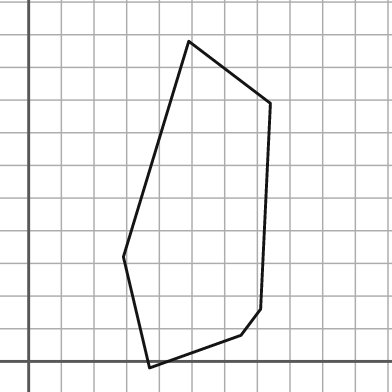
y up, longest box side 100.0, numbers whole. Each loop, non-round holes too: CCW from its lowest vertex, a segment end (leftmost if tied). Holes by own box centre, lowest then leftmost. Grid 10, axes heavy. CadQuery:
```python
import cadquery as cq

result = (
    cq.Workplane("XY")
    .moveTo(37.0, -2.0)
    .lineTo(65.0, 8.0)
    .lineTo(71.0, 16.0)
    .lineTo(74.0, 79.0)
    .lineTo(49.0, 98.0)
    .lineTo(29.0, 32.0)
    .close()
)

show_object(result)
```